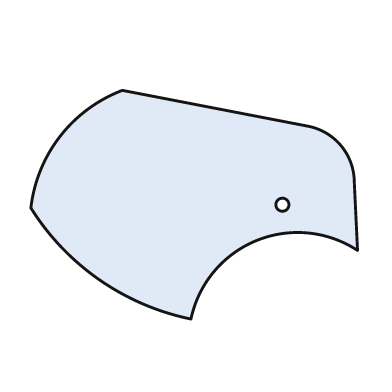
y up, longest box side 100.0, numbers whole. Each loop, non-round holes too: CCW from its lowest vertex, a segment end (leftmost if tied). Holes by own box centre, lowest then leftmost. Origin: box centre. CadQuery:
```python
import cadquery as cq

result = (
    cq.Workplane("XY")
    .moveTo(-1.0, -35.0)
    .threePointArc((19.0, -11.0), (50.0, -14.0))
    .lineTo(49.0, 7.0)
    .threePointArc((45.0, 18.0), (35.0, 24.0))
    .lineTo(-22.0, 35.0)
    .threePointArc((-41.0, 21.0), (-50.0, -1.0))
    .threePointArc((-29.0, -23.0), (-1.0, -35.0))
    .close()
    .moveTo(27.0, 0.0)
    .circle(2.0)
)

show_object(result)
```